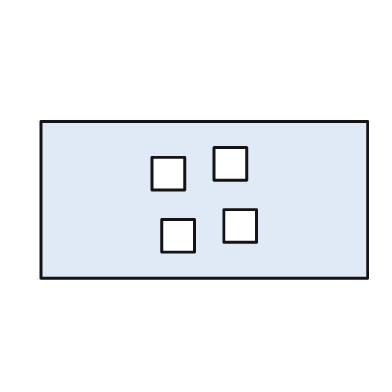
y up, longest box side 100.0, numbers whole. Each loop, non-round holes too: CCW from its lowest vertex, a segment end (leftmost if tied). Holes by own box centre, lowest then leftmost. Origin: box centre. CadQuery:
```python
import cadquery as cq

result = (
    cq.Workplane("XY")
    .moveTo(-50.0, -24.0)
    .lineTo(50.0, -24.0)
    .lineTo(50.0, 24.0)
    .lineTo(-50.0, 24.0)
    .close()
    .moveTo(-13.0, -16.0)
    .lineTo(-3.0, -16.0)
    .lineTo(-3.0, -6.0)
    .lineTo(-13.0, -6.0)
    .close()
    .moveTo(6.0, -13.0)
    .lineTo(16.0, -13.0)
    .lineTo(16.0, -3.0)
    .lineTo(6.0, -3.0)
    .close()
    .moveTo(-16.0, 3.0)
    .lineTo(-6.0, 3.0)
    .lineTo(-6.0, 13.0)
    .lineTo(-16.0, 13.0)
    .close()
    .moveTo(3.0, 6.0)
    .lineTo(13.0, 6.0)
    .lineTo(13.0, 16.0)
    .lineTo(3.0, 16.0)
    .close()
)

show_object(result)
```